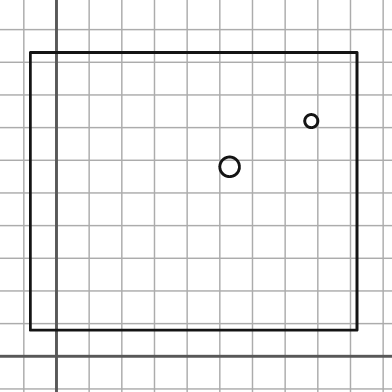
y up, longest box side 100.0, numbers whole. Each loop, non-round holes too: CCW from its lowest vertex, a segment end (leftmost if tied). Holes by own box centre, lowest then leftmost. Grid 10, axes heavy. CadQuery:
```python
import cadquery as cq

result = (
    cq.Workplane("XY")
    .moveTo(-8.0, 8.0)
    .lineTo(92.0, 8.0)
    .lineTo(92.0, 93.0)
    .lineTo(-8.0, 93.0)
    .close()
    .moveTo(53.0, 58.0)
    .circle(3.0)
    .moveTo(78.0, 72.0)
    .circle(2.0)
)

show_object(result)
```